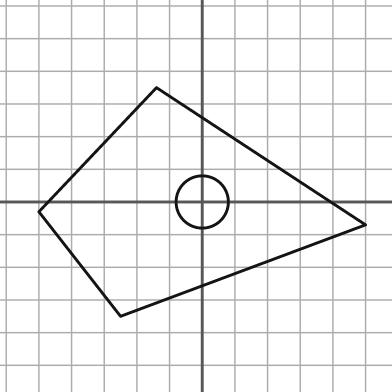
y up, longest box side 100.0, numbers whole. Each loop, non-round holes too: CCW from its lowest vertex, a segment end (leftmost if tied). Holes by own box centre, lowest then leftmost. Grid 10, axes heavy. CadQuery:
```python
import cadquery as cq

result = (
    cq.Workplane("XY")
    .moveTo(-25.0, -35.0)
    .lineTo(50.0, -7.0)
    .lineTo(-14.0, 35.0)
    .lineTo(-50.0, -3.0)
    .close()
    .moveTo(0.0, 0.0)
    .circle(8.0)
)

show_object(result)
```